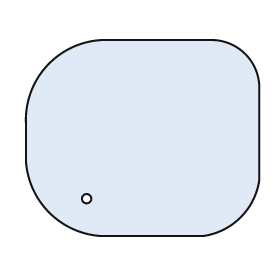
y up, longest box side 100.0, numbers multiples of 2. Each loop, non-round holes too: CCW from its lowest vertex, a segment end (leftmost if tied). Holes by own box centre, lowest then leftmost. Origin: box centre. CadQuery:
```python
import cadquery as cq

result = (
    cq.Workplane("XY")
    .moveTo(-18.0, -42.0)
    .lineTo(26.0, -42.0)
    .threePointArc((42.0, -34.0), (50.0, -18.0))
    .lineTo(50.0, 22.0)
    .threePointArc((44.0, 36.0), (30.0, 42.0))
    .lineTo(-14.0, 42.0)
    .threePointArc((-40.0, 32.0), (-50.0, 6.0))
    .lineTo(-50.0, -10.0)
    .threePointArc((-40.0, -32.0), (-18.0, -42.0))
    .close()
    .moveTo(-24.0, -26.0)
    .circle(2.0)
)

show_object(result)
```